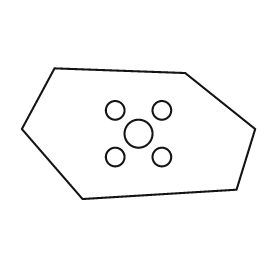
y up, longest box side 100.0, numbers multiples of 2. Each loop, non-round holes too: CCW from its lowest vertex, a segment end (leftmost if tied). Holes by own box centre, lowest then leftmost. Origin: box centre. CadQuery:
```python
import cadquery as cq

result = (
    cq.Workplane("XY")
    .moveTo(-24.0, -28.0)
    .lineTo(42.0, -24.0)
    .lineTo(50.0, 2.0)
    .lineTo(20.0, 26.0)
    .lineTo(-36.0, 28.0)
    .lineTo(-50.0, 2.0)
    .close()
    .moveTo(-10.0, -10.0)
    .circle(4.0)
    .moveTo(10.0, -10.0)
    .circle(4.0)
    .moveTo(0.0, 0.0)
    .circle(6.0)
    .moveTo(-10.0, 10.0)
    .circle(4.0)
    .moveTo(10.0, 10.0)
    .circle(4.0)
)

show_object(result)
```